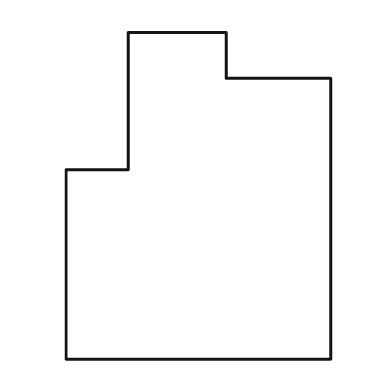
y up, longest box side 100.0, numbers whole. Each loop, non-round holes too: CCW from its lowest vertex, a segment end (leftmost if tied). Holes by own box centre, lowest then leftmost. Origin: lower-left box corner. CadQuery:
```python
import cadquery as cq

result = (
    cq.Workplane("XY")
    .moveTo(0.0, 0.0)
    .lineTo(81.0, 0.0)
    .lineTo(81.0, 86.0)
    .lineTo(49.0, 86.0)
    .lineTo(49.0, 100.0)
    .lineTo(19.0, 100.0)
    .lineTo(19.0, 58.0)
    .lineTo(0.0, 58.0)
    .close()
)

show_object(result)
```